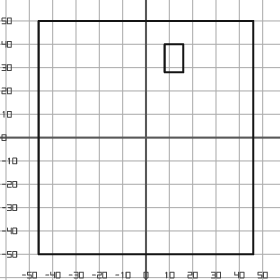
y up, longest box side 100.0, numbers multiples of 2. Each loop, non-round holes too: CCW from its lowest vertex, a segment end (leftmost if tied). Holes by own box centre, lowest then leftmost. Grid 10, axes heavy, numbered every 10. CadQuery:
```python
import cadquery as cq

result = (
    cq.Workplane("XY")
    .moveTo(-46.0, -50.0)
    .lineTo(46.0, -50.0)
    .lineTo(46.0, 50.0)
    .lineTo(-46.0, 50.0)
    .close()
    .moveTo(8.0, 28.0)
    .lineTo(16.0, 28.0)
    .lineTo(16.0, 40.0)
    .lineTo(8.0, 40.0)
    .close()
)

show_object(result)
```